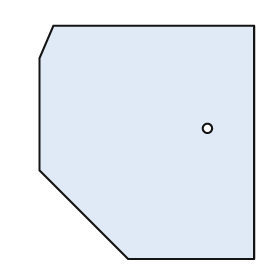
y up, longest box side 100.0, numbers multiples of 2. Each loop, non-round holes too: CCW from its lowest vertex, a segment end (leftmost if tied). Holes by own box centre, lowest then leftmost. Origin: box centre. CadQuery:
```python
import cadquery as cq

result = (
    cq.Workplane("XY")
    .moveTo(-8.0, -50.0)
    .lineTo(46.0, -50.0)
    .lineTo(46.0, 50.0)
    .lineTo(-40.0, 50.0)
    .lineTo(-46.0, 36.0)
    .lineTo(-46.0, -12.0)
    .close()
    .moveTo(26.0, 6.0)
    .circle(2.0)
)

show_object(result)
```